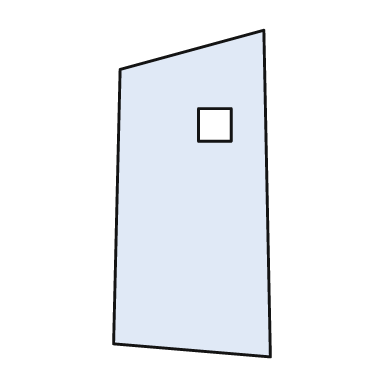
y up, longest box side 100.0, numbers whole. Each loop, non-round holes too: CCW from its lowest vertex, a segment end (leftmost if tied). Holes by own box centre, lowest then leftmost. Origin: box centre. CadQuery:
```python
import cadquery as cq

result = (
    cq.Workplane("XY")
    .moveTo(24.0, -50.0)
    .lineTo(22.0, 50.0)
    .lineTo(-22.0, 38.0)
    .lineTo(-24.0, -46.0)
    .close()
    .moveTo(2.0, 16.0)
    .lineTo(12.0, 16.0)
    .lineTo(12.0, 26.0)
    .lineTo(2.0, 26.0)
    .close()
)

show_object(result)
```